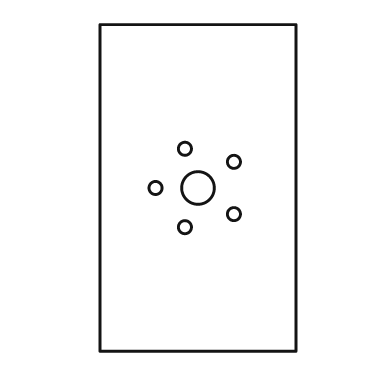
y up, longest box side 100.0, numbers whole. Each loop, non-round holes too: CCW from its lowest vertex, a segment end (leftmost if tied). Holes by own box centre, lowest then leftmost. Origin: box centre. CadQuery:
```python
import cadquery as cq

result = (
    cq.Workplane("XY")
    .moveTo(-30.0, -50.0)
    .lineTo(30.0, -50.0)
    .lineTo(30.0, 50.0)
    .lineTo(-30.0, 50.0)
    .close()
    .moveTo(-4.0, -12.0)
    .circle(2.0)
    .moveTo(11.0, -8.0)
    .circle(2.0)
    .moveTo(-13.0, 0.0)
    .circle(2.0)
    .moveTo(0.0, 0.0)
    .circle(5.0)
    .moveTo(11.0, 8.0)
    .circle(2.0)
    .moveTo(-4.0, 12.0)
    .circle(2.0)
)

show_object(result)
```